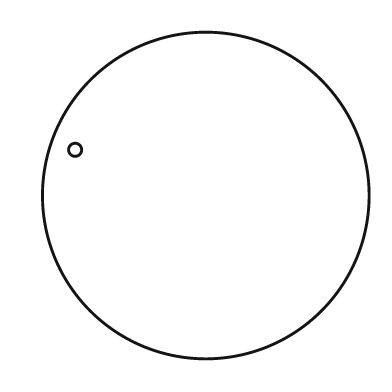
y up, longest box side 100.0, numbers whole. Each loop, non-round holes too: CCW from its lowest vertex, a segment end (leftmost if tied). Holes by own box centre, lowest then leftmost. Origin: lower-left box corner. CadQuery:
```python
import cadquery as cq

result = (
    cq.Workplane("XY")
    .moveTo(50.0, 50.0)
    .circle(50.0)
    .moveTo(10.0, 64.0)
    .circle(2.0)
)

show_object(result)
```